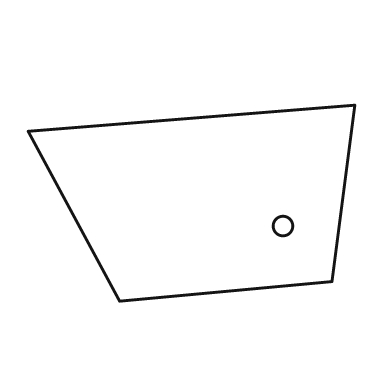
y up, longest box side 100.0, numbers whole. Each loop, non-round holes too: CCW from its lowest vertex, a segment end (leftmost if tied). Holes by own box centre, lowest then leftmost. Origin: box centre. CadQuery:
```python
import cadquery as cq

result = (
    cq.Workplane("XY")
    .moveTo(-22.0, -30.0)
    .lineTo(43.0, -24.0)
    .lineTo(50.0, 30.0)
    .lineTo(-50.0, 22.0)
    .close()
    .moveTo(28.0, -7.0)
    .circle(3.0)
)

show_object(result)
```